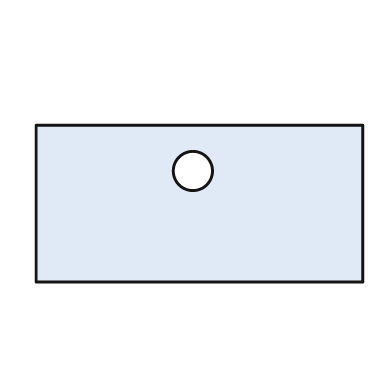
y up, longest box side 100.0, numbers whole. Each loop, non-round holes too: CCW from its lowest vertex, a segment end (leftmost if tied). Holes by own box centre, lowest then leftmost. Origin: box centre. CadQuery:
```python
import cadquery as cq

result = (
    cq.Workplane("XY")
    .moveTo(-50.0, -24.0)
    .lineTo(50.0, -24.0)
    .lineTo(50.0, 24.0)
    .lineTo(-50.0, 24.0)
    .close()
    .moveTo(-2.0, 10.0)
    .circle(6.0)
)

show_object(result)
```